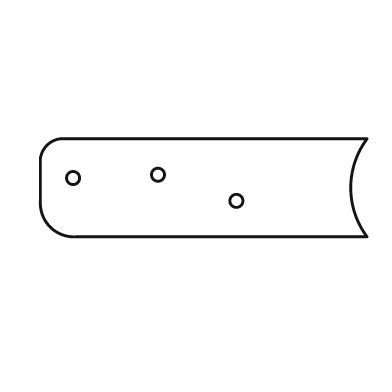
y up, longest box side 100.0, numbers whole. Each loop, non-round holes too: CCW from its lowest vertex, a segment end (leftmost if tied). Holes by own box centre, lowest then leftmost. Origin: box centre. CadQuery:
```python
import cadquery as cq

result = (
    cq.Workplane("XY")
    .moveTo(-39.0, -15.0)
    .lineTo(50.0, -15.0)
    .threePointArc((45.0, 0.0), (50.0, 15.0))
    .lineTo(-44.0, 15.0)
    .threePointArc((-48.0, 13.0), (-50.0, 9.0))
    .lineTo(-50.0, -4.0)
    .threePointArc((-47.0, -12.0), (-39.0, -15.0))
    .close()
    .moveTo(10.0, -4.0)
    .circle(2.0)
    .moveTo(-40.0, 3.0)
    .circle(2.0)
    .moveTo(-14.0, 4.0)
    .circle(2.0)
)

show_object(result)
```